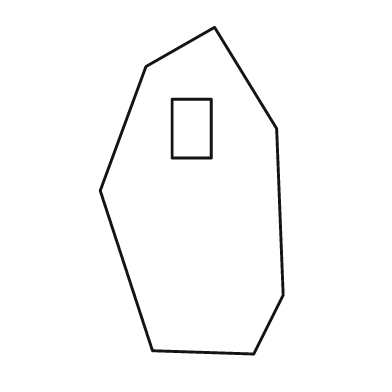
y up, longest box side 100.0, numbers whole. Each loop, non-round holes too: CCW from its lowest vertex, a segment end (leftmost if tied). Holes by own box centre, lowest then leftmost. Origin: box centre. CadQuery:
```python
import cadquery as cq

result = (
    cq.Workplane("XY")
    .moveTo(19.0, -50.0)
    .lineTo(28.0, -32.0)
    .lineTo(26.0, 19.0)
    .lineTo(7.0, 50.0)
    .lineTo(-14.0, 38.0)
    .lineTo(-28.0, 0.0)
    .lineTo(-12.0, -49.0)
    .close()
    .moveTo(-6.0, 10.0)
    .lineTo(6.0, 10.0)
    .lineTo(6.0, 28.0)
    .lineTo(-6.0, 28.0)
    .close()
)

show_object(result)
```